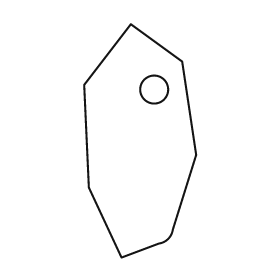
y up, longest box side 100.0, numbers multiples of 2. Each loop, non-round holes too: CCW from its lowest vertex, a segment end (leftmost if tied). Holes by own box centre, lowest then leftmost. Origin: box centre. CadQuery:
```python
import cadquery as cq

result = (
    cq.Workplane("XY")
    .moveTo(-8.0, -50.0)
    .lineTo(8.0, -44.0)
    .threePointArc((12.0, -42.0), (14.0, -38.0))
    .lineTo(24.0, -6.0)
    .lineTo(18.0, 34.0)
    .lineTo(-4.0, 50.0)
    .lineTo(-24.0, 24.0)
    .lineTo(-22.0, -20.0)
    .close()
    .moveTo(6.0, 22.0)
    .circle(6.0)
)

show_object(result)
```